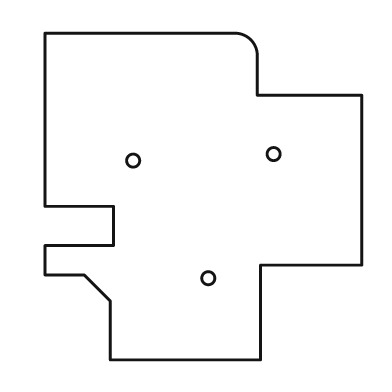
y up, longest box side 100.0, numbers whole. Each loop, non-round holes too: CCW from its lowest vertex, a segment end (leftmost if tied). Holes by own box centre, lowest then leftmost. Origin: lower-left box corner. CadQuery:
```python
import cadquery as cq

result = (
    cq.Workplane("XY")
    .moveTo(20.0, 0.0)
    .lineTo(66.0, 0.0)
    .lineTo(66.0, 29.0)
    .lineTo(97.0, 29.0)
    .lineTo(97.0, 81.0)
    .lineTo(65.0, 81.0)
    .lineTo(65.0, 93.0)
    .threePointArc((63.0, 98.0), (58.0, 100.0))
    .lineTo(0.0, 100.0)
    .lineTo(0.0, 47.0)
    .lineTo(21.0, 47.0)
    .lineTo(21.0, 35.0)
    .lineTo(0.0, 35.0)
    .lineTo(0.0, 26.0)
    .lineTo(12.0, 26.0)
    .lineTo(20.0, 18.0)
    .close()
    .moveTo(50.0, 25.0)
    .circle(2.0)
    .moveTo(27.0, 61.0)
    .circle(2.0)
    .moveTo(70.0, 63.0)
    .circle(2.0)
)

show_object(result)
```